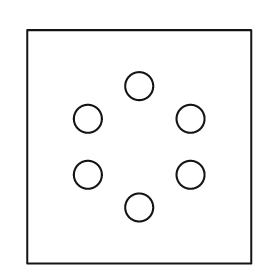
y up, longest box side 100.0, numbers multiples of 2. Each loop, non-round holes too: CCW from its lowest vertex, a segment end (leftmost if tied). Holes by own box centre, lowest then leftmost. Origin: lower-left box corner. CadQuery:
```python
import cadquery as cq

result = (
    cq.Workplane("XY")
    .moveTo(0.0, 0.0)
    .lineTo(96.0, 0.0)
    .lineTo(96.0, 100.0)
    .lineTo(0.0, 100.0)
    .close()
    .moveTo(48.0, 24.0)
    .circle(6.0)
    .moveTo(26.0, 38.0)
    .circle(6.0)
    .moveTo(70.0, 38.0)
    .circle(6.0)
    .moveTo(26.0, 62.0)
    .circle(6.0)
    .moveTo(70.0, 62.0)
    .circle(6.0)
    .moveTo(48.0, 76.0)
    .circle(6.0)
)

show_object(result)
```